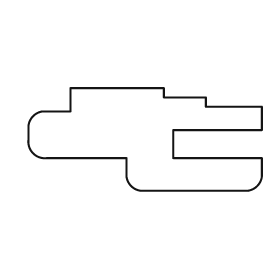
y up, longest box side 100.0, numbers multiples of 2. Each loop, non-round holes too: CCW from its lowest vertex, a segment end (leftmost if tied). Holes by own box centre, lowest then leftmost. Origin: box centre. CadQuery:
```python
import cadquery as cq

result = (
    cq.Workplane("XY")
    .moveTo(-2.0, -22.0)
    .lineTo(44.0, -22.0)
    .threePointArc((48.0, -20.0), (50.0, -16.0))
    .lineTo(50.0, -8.0)
    .lineTo(12.0, -8.0)
    .lineTo(12.0, 4.0)
    .lineTo(50.0, 4.0)
    .lineTo(50.0, 14.0)
    .lineTo(26.0, 14.0)
    .lineTo(26.0, 18.0)
    .lineTo(8.0, 18.0)
    .lineTo(8.0, 22.0)
    .lineTo(-32.0, 22.0)
    .lineTo(-32.0, 12.0)
    .lineTo(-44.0, 12.0)
    .threePointArc((-48.0, 10.0), (-50.0, 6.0))
    .lineTo(-50.0, 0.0)
    .threePointArc((-48.0, -6.0), (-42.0, -8.0))
    .lineTo(-8.0, -8.0)
    .lineTo(-8.0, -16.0)
    .threePointArc((-6.0, -20.0), (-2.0, -22.0))
    .close()
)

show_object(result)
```